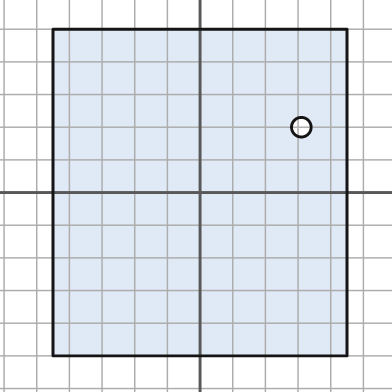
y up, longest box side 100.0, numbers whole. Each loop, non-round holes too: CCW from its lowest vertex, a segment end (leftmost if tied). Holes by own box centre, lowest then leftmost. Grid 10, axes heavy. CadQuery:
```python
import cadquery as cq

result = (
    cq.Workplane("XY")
    .moveTo(-45.0, -50.0)
    .lineTo(45.0, -50.0)
    .lineTo(45.0, 50.0)
    .lineTo(-45.0, 50.0)
    .close()
    .moveTo(31.0, 20.0)
    .circle(3.0)
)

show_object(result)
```